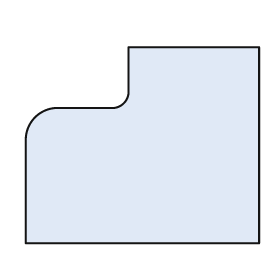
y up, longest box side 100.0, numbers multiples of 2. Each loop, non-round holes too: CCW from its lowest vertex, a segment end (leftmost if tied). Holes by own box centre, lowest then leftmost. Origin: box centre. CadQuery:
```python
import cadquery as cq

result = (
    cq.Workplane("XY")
    .moveTo(-50.0, -42.0)
    .lineTo(50.0, -42.0)
    .lineTo(50.0, 42.0)
    .lineTo(-6.0, 42.0)
    .lineTo(-6.0, 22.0)
    .threePointArc((-8.0, 18.0), (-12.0, 16.0))
    .lineTo(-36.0, 16.0)
    .threePointArc((-46.0, 12.0), (-50.0, 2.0))
    .close()
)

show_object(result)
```